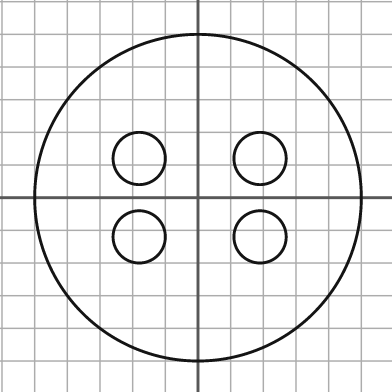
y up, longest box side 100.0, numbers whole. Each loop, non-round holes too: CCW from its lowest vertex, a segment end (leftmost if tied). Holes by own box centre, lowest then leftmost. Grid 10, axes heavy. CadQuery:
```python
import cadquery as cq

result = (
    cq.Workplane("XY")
    .moveTo(0.0, 0.0)
    .circle(50.0)
    .moveTo(-18.0, -12.0)
    .circle(8.0)
    .moveTo(19.0, -12.0)
    .circle(8.0)
    .moveTo(-18.0, 12.0)
    .circle(8.0)
    .moveTo(19.0, 12.0)
    .circle(8.0)
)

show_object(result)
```